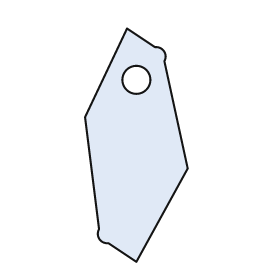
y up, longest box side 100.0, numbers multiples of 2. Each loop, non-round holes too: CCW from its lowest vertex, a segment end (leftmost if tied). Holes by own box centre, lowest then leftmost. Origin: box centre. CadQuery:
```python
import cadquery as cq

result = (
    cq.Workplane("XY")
    .moveTo(0.0, -50.0)
    .lineTo(22.0, -10.0)
    .lineTo(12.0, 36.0)
    .threePointArc((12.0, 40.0), (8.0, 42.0))
    .lineTo(-4.0, 50.0)
    .lineTo(-22.0, 12.0)
    .lineTo(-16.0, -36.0)
    .threePointArc((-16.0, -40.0), (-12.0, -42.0))
    .close()
    .moveTo(0.0, 28.0)
    .circle(6.0)
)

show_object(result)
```